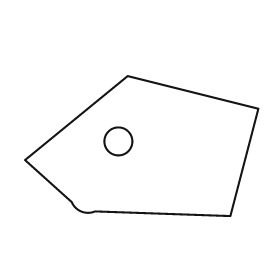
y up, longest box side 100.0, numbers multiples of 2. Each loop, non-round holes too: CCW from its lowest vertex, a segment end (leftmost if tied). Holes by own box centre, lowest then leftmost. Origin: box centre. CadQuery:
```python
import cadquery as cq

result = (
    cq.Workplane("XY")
    .moveTo(38.0, -30.0)
    .lineTo(50.0, 16.0)
    .lineTo(-6.0, 30.0)
    .lineTo(-50.0, -6.0)
    .lineTo(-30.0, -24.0)
    .threePointArc((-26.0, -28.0), (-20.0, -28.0))
    .close()
    .moveTo(-10.0, 2.0)
    .circle(6.0)
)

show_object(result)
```